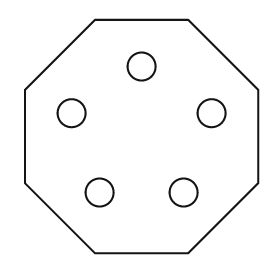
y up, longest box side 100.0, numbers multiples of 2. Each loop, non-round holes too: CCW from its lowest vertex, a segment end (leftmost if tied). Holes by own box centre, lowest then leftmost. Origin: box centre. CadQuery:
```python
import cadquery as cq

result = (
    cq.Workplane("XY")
    .moveTo(-20.0, -50.0)
    .lineTo(20.0, -50.0)
    .lineTo(50.0, -20.0)
    .lineTo(50.0, 20.0)
    .lineTo(20.0, 50.0)
    .lineTo(-20.0, 50.0)
    .lineTo(-50.0, 20.0)
    .lineTo(-50.0, -20.0)
    .close()
    .moveTo(-18.0, -24.0)
    .circle(6.0)
    .moveTo(18.0, -24.0)
    .circle(6.0)
    .moveTo(-30.0, 10.0)
    .circle(6.0)
    .moveTo(30.0, 10.0)
    .circle(6.0)
    .moveTo(0.0, 30.0)
    .circle(6.0)
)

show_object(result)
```